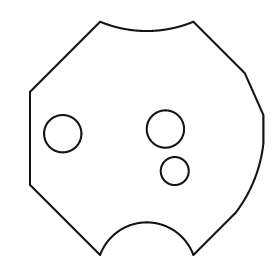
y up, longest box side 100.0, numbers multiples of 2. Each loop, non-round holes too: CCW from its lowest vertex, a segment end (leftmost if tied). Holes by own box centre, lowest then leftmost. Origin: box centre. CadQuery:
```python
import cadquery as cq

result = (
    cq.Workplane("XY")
    .moveTo(-20.0, -50.0)
    .threePointArc((0.0, -36.0), (20.0, -50.0))
    .lineTo(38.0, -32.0)
    .threePointArc((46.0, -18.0), (50.0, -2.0))
    .lineTo(50.0, 10.0)
    .lineTo(42.0, 28.0)
    .lineTo(20.0, 50.0)
    .threePointArc((0.0, 46.0), (-20.0, 50.0))
    .lineTo(-50.0, 20.0)
    .lineTo(-50.0, -20.0)
    .close()
    .moveTo(12.0, -14.0)
    .circle(6.0)
    .moveTo(-36.0, 2.0)
    .circle(8.0)
    .moveTo(8.0, 4.0)
    .circle(8.0)
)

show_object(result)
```